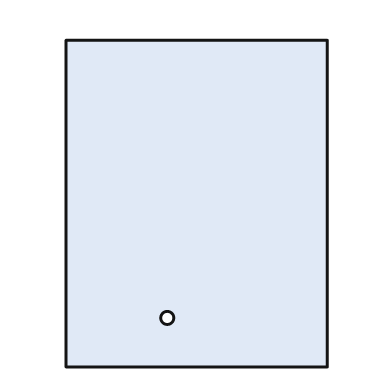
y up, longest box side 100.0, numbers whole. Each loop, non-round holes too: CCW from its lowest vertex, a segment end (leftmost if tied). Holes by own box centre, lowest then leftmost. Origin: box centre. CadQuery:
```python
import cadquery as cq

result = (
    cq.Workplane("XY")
    .moveTo(-40.0, -50.0)
    .lineTo(40.0, -50.0)
    .lineTo(40.0, 50.0)
    .lineTo(-40.0, 50.0)
    .close()
    .moveTo(-9.0, -35.0)
    .circle(2.0)
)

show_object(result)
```